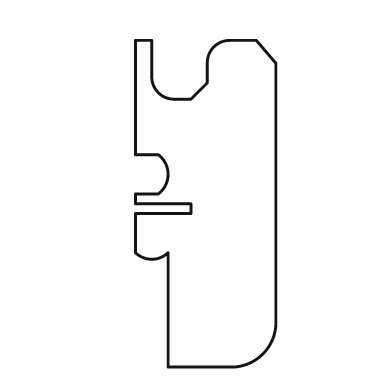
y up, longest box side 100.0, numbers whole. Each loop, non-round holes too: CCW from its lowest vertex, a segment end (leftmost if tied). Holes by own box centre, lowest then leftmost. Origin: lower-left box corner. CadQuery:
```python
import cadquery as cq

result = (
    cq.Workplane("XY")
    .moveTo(10.0, 0.0)
    .lineTo(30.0, 0.0)
    .threePointArc((39.0, 4.0), (43.0, 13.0))
    .lineTo(43.0, 93.0)
    .lineTo(37.0, 100.0)
    .lineTo(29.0, 100.0)
    .threePointArc((24.0, 98.0), (22.0, 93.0))
    .lineTo(22.0, 87.0)
    .lineTo(17.0, 82.0)
    .lineTo(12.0, 82.0)
    .threePointArc((7.0, 84.0), (5.0, 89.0))
    .lineTo(5.0, 100.0)
    .lineTo(0.0, 100.0)
    .lineTo(0.0, 65.0)
    .lineTo(7.0, 65.0)
    .threePointArc((10.0, 59.0), (7.0, 53.0))
    .lineTo(0.0, 53.0)
    .lineTo(0.0, 50.0)
    .lineTo(17.0, 50.0)
    .lineTo(17.0, 47.0)
    .lineTo(0.0, 47.0)
    .lineTo(0.0, 35.0)
    .threePointArc((5.0, 33.0), (10.0, 35.0))
    .close()
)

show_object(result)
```